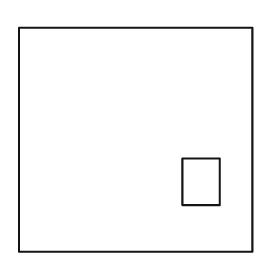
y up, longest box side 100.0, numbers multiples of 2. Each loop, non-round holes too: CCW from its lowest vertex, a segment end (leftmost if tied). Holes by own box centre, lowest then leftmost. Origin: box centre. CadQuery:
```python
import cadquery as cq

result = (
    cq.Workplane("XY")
    .moveTo(-50.0, -48.0)
    .lineTo(50.0, -48.0)
    .lineTo(50.0, 48.0)
    .lineTo(-50.0, 48.0)
    .close()
    .moveTo(20.0, -28.0)
    .lineTo(36.0, -28.0)
    .lineTo(36.0, -8.0)
    .lineTo(20.0, -8.0)
    .close()
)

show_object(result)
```